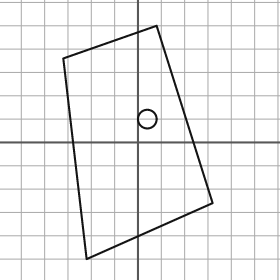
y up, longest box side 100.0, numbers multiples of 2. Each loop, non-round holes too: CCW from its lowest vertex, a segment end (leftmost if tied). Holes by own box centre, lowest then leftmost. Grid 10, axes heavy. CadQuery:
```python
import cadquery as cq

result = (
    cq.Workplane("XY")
    .moveTo(-22.0, -50.0)
    .lineTo(32.0, -26.0)
    .lineTo(8.0, 50.0)
    .lineTo(-32.0, 36.0)
    .close()
    .moveTo(4.0, 10.0)
    .circle(4.0)
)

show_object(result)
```